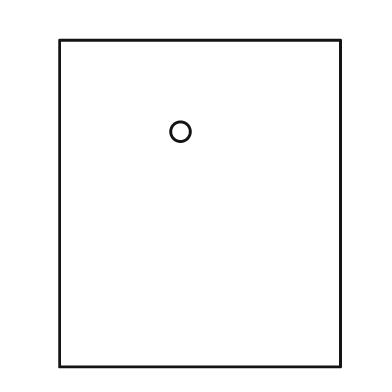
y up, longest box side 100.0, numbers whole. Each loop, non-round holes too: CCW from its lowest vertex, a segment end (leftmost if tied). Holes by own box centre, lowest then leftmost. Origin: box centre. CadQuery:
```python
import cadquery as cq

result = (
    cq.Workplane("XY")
    .moveTo(-43.0, -50.0)
    .lineTo(43.0, -50.0)
    .lineTo(43.0, 50.0)
    .lineTo(-43.0, 50.0)
    .close()
    .moveTo(-6.0, 22.0)
    .circle(3.0)
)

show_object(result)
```